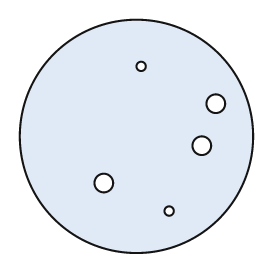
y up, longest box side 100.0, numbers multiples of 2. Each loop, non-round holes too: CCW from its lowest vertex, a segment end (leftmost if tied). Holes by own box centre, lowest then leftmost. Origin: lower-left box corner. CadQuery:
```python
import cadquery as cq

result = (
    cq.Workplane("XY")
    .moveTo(50.0, 50.0)
    .circle(50.0)
    .moveTo(64.0, 18.0)
    .circle(2.0)
    .moveTo(36.0, 30.0)
    .circle(4.0)
    .moveTo(78.0, 46.0)
    .circle(4.0)
    .moveTo(84.0, 64.0)
    .circle(4.0)
    .moveTo(52.0, 80.0)
    .circle(2.0)
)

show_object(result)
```